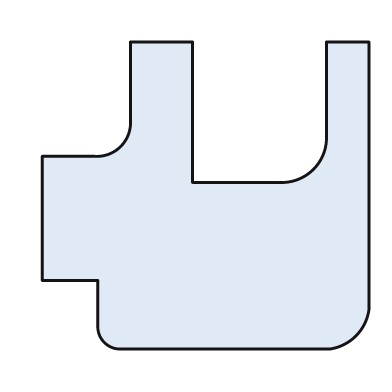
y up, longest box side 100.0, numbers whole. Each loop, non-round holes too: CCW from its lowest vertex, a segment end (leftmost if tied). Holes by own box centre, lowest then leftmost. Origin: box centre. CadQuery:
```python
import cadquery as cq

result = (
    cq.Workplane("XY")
    .moveTo(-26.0, -47.0)
    .lineTo(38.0, -47.0)
    .threePointArc((46.0, -43.0), (50.0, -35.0))
    .lineTo(50.0, 47.0)
    .lineTo(37.0, 47.0)
    .lineTo(37.0, 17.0)
    .threePointArc((33.0, 8.0), (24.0, 4.0))
    .lineTo(-4.0, 4.0)
    .lineTo(-4.0, 47.0)
    .lineTo(-23.0, 47.0)
    .lineTo(-23.0, 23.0)
    .threePointArc((-26.0, 15.0), (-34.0, 12.0))
    .lineTo(-50.0, 12.0)
    .lineTo(-50.0, -26.0)
    .lineTo(-33.0, -26.0)
    .lineTo(-33.0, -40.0)
    .threePointArc((-31.0, -45.0), (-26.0, -47.0))
    .close()
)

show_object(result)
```